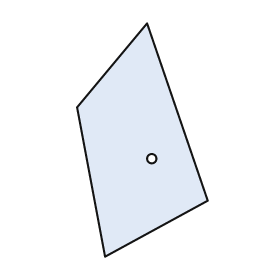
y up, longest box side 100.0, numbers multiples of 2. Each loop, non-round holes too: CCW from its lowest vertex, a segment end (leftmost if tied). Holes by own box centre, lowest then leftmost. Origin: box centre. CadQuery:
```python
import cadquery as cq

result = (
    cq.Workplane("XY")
    .moveTo(-16.0, -50.0)
    .lineTo(28.0, -26.0)
    .lineTo(2.0, 50.0)
    .lineTo(-28.0, 14.0)
    .close()
    .moveTo(4.0, -8.0)
    .circle(2.0)
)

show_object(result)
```